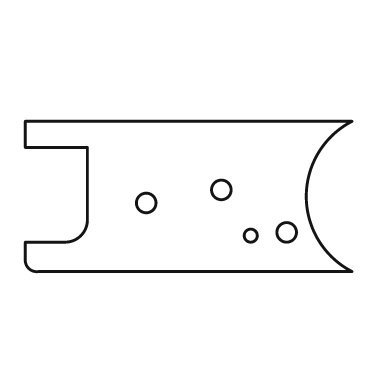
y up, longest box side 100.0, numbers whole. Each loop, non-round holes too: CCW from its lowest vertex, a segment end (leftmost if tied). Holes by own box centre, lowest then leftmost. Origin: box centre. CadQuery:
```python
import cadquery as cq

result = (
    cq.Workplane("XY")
    .moveTo(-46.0, -23.0)
    .lineTo(50.0, -23.0)
    .threePointArc((36.0, 0.0), (50.0, 23.0))
    .lineTo(-50.0, 23.0)
    .lineTo(-50.0, 15.0)
    .lineTo(-31.0, 15.0)
    .lineTo(-31.0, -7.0)
    .threePointArc((-33.0, -12.0), (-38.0, -14.0))
    .lineTo(-50.0, -14.0)
    .lineTo(-50.0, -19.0)
    .threePointArc((-49.0, -22.0), (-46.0, -23.0))
    .close()
    .moveTo(19.0, -12.0)
    .circle(2.0)
    .moveTo(30.0, -11.0)
    .circle(3.0)
    .moveTo(-13.0, -2.0)
    .circle(3.0)
    .moveTo(10.0, 2.0)
    .circle(3.0)
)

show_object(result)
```